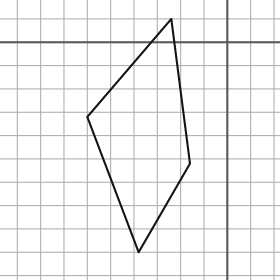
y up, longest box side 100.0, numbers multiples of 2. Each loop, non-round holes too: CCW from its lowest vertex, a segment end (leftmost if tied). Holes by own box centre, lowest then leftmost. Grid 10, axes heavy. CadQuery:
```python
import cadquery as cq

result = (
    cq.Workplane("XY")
    .moveTo(-38.0, -90.0)
    .lineTo(-16.0, -52.0)
    .lineTo(-24.0, 10.0)
    .lineTo(-60.0, -32.0)
    .close()
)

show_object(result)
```